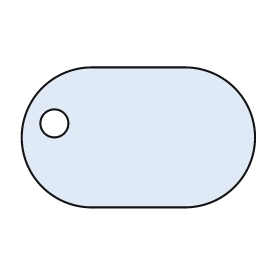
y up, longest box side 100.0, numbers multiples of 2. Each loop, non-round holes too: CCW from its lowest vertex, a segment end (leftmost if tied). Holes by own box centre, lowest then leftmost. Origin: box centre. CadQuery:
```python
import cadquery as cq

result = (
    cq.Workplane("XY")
    .moveTo(-20.0, -30.0)
    .lineTo(20.0, -30.0)
    .threePointArc((50.0, 0.0), (20.0, 30.0))
    .lineTo(-20.0, 30.0)
    .threePointArc((-50.0, 0.0), (-20.0, -30.0))
    .close()
    .moveTo(-36.0, 6.0)
    .circle(6.0)
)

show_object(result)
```